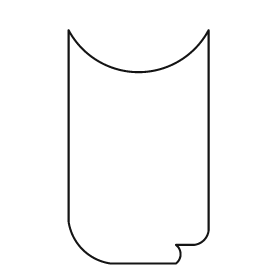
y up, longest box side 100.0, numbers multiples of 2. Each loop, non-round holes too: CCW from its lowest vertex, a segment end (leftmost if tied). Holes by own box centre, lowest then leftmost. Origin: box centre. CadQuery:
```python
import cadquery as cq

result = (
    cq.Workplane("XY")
    .moveTo(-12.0, -50.0)
    .lineTo(16.0, -50.0)
    .threePointArc((18.0, -46.0), (16.0, -42.0))
    .lineTo(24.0, -42.0)
    .threePointArc((28.0, -40.0), (30.0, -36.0))
    .lineTo(30.0, 50.0)
    .threePointArc((0.0, 32.0), (-30.0, 50.0))
    .lineTo(-30.0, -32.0)
    .threePointArc((-24.0, -44.0), (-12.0, -50.0))
    .close()
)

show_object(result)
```